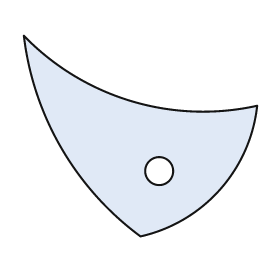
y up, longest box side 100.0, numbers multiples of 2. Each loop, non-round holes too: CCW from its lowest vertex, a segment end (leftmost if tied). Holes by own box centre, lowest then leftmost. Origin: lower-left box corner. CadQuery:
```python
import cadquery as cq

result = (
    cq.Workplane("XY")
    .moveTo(50.0, 0.0)
    .threePointArc((84.0, 20.0), (100.0, 56.0))
    .threePointArc((46.0, 58.0), (0.0, 86.0))
    .threePointArc((16.0, 38.0), (50.0, 0.0))
    .close()
    .moveTo(58.0, 28.0)
    .circle(6.0)
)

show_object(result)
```